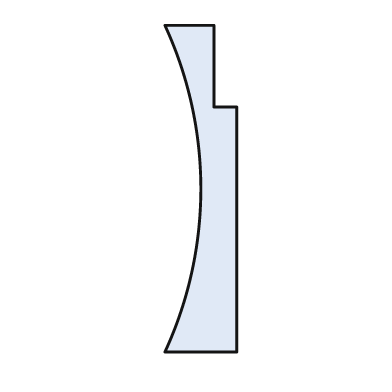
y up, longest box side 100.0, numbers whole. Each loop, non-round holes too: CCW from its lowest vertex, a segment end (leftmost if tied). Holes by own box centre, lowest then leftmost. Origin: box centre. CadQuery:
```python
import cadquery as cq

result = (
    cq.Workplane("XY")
    .moveTo(-11.0, -50.0)
    .lineTo(11.0, -50.0)
    .lineTo(11.0, 25.0)
    .lineTo(4.0, 25.0)
    .lineTo(4.0, 50.0)
    .lineTo(-11.0, 50.0)
    .threePointArc((0.0, 0.0), (-11.0, -50.0))
    .close()
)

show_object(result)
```